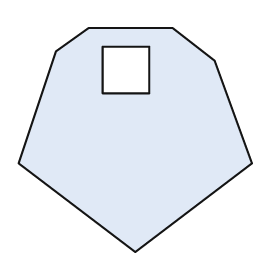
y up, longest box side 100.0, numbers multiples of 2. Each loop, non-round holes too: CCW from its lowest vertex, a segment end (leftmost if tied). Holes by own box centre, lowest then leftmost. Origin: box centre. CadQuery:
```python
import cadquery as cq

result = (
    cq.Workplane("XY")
    .moveTo(0.0, -48.0)
    .lineTo(50.0, -10.0)
    .lineTo(34.0, 34.0)
    .lineTo(16.0, 48.0)
    .lineTo(-20.0, 48.0)
    .lineTo(-34.0, 38.0)
    .lineTo(-50.0, -10.0)
    .close()
    .moveTo(-14.0, 20.0)
    .lineTo(6.0, 20.0)
    .lineTo(6.0, 40.0)
    .lineTo(-14.0, 40.0)
    .close()
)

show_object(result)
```